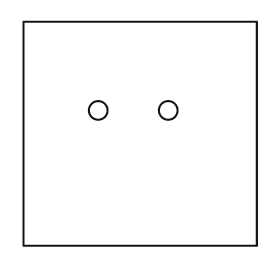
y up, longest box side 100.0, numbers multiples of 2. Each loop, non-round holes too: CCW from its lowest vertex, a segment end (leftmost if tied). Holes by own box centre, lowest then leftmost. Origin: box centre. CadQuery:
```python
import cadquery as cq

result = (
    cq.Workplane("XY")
    .moveTo(-50.0, -48.0)
    .lineTo(50.0, -48.0)
    .lineTo(50.0, 48.0)
    .lineTo(-50.0, 48.0)
    .close()
    .moveTo(-18.0, 10.0)
    .circle(4.0)
    .moveTo(12.0, 10.0)
    .circle(4.0)
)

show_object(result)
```